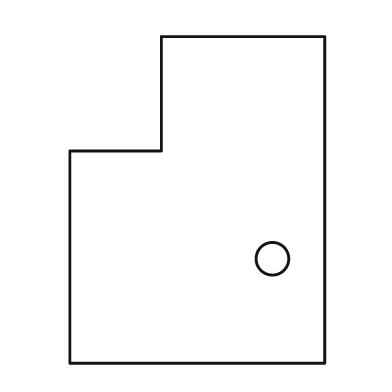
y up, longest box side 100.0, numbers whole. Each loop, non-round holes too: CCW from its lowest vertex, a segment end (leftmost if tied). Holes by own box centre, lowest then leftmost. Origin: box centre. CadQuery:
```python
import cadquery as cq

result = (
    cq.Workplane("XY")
    .moveTo(-39.0, -50.0)
    .lineTo(39.0, -50.0)
    .lineTo(39.0, 50.0)
    .lineTo(-11.0, 50.0)
    .lineTo(-11.0, 15.0)
    .lineTo(-39.0, 15.0)
    .close()
    .moveTo(23.0, -18.0)
    .circle(5.0)
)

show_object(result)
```